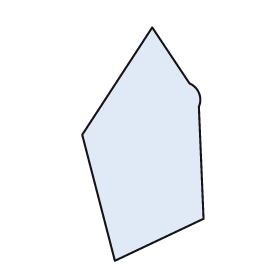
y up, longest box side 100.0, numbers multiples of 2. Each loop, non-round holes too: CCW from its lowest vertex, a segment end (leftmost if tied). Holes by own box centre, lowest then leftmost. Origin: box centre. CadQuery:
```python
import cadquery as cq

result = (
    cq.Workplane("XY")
    .moveTo(-12.0, -50.0)
    .lineTo(26.0, -32.0)
    .lineTo(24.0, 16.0)
    .threePointArc((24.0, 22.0), (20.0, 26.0))
    .lineTo(4.0, 50.0)
    .lineTo(-26.0, 4.0)
    .close()
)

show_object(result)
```